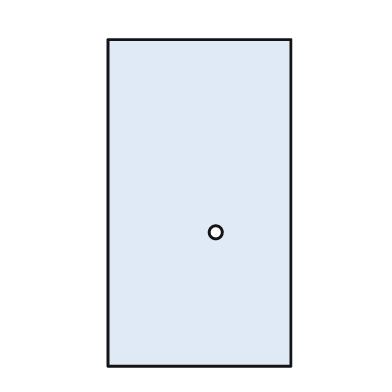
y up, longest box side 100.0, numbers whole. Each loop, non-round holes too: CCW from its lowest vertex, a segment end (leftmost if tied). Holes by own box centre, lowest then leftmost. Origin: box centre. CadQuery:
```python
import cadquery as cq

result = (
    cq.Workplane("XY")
    .moveTo(-28.0, -50.0)
    .lineTo(28.0, -50.0)
    .lineTo(28.0, 50.0)
    .lineTo(-28.0, 50.0)
    .close()
    .moveTo(5.0, -9.0)
    .circle(2.0)
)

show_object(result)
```